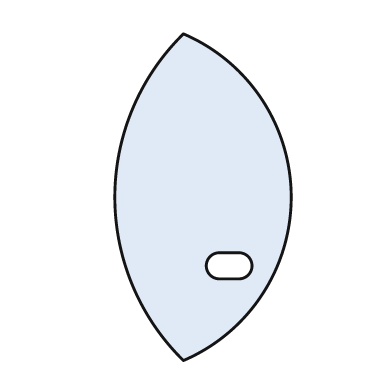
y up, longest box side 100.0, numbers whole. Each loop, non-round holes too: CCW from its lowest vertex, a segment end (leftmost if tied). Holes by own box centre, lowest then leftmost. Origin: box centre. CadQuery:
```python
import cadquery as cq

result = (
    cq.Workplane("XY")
    .moveTo(-6.0, -50.0)
    .threePointArc((27.0, 0.0), (-6.0, 50.0))
    .threePointArc((-27.0, 0.0), (-6.0, -50.0))
    .close()
    .moveTo(5.0, -25.0)
    .lineTo(11.0, -25.0)
    .threePointArc((15.0, -21.0), (11.0, -17.0))
    .lineTo(5.0, -17.0)
    .threePointArc((1.0, -21.0), (5.0, -25.0))
    .close()
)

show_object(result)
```